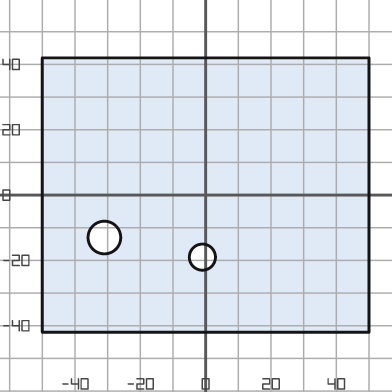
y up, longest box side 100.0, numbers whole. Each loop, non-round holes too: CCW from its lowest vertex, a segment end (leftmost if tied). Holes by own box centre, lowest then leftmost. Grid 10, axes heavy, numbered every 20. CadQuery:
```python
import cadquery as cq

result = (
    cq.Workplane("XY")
    .moveTo(-50.0, -42.0)
    .lineTo(50.0, -42.0)
    .lineTo(50.0, 42.0)
    .lineTo(-50.0, 42.0)
    .close()
    .moveTo(-1.0, -19.0)
    .circle(4.0)
    .moveTo(-31.0, -13.0)
    .circle(5.0)
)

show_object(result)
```